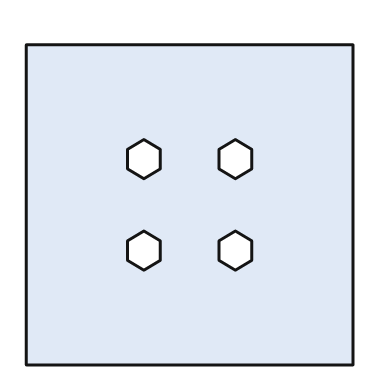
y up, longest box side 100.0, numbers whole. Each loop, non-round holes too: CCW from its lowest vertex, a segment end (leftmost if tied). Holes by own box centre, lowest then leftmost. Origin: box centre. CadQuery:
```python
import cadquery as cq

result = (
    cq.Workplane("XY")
    .moveTo(-50.0, -49.0)
    .lineTo(50.0, -49.0)
    .lineTo(50.0, 49.0)
    .lineTo(-50.0, 49.0)
    .close()
    .moveTo(-14.0, -20.0)
    .lineTo(-9.0, -17.0)
    .lineTo(-9.0, -11.0)
    .lineTo(-14.0, -8.0)
    .lineTo(-19.0, -11.0)
    .lineTo(-19.0, -17.0)
    .close()
    .moveTo(14.0, -20.0)
    .lineTo(19.0, -17.0)
    .lineTo(19.0, -11.0)
    .lineTo(14.0, -8.0)
    .lineTo(9.0, -11.0)
    .lineTo(9.0, -17.0)
    .close()
    .moveTo(-14.0, 8.0)
    .lineTo(-9.0, 11.0)
    .lineTo(-9.0, 17.0)
    .lineTo(-14.0, 20.0)
    .lineTo(-19.0, 17.0)
    .lineTo(-19.0, 11.0)
    .close()
    .moveTo(14.0, 8.0)
    .lineTo(19.0, 11.0)
    .lineTo(19.0, 17.0)
    .lineTo(14.0, 20.0)
    .lineTo(9.0, 17.0)
    .lineTo(9.0, 11.0)
    .close()
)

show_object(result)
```